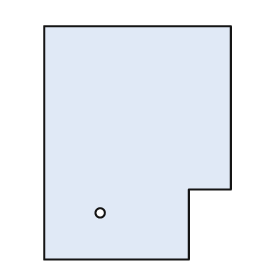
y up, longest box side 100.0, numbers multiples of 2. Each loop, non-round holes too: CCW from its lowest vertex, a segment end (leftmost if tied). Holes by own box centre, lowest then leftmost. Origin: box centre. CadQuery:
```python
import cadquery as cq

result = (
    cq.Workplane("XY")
    .moveTo(-40.0, -50.0)
    .lineTo(22.0, -50.0)
    .lineTo(22.0, -20.0)
    .lineTo(40.0, -20.0)
    .lineTo(40.0, 50.0)
    .lineTo(-40.0, 50.0)
    .close()
    .moveTo(-16.0, -30.0)
    .circle(2.0)
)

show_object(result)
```